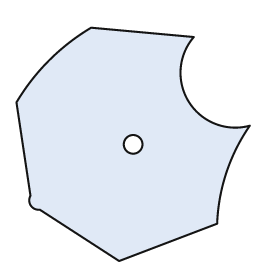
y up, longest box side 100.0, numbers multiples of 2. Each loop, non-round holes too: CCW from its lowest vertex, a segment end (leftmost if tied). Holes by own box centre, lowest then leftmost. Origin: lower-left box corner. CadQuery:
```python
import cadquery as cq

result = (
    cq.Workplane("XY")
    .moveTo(44.0, 0.0)
    .lineTo(86.0, 16.0)
    .threePointArc((90.0, 38.0), (100.0, 58.0))
    .threePointArc((74.0, 68.0), (76.0, 96.0))
    .lineTo(32.0, 100.0)
    .threePointArc((14.0, 86.0), (0.0, 68.0))
    .lineTo(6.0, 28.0)
    .threePointArc((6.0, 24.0), (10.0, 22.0))
    .close()
    .moveTo(50.0, 50.0)
    .circle(4.0)
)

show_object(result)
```